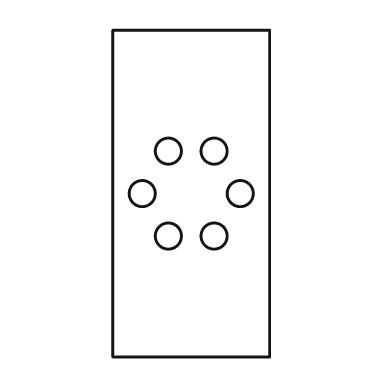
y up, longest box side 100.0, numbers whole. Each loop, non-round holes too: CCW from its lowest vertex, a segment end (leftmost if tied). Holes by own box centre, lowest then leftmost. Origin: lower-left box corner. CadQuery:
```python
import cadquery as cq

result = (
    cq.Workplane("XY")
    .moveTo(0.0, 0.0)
    .lineTo(48.0, 0.0)
    .lineTo(48.0, 100.0)
    .lineTo(0.0, 100.0)
    .close()
    .moveTo(17.0, 37.0)
    .circle(4.0)
    .moveTo(31.0, 37.0)
    .circle(4.0)
    .moveTo(9.0, 50.0)
    .circle(4.0)
    .moveTo(39.0, 50.0)
    .circle(4.0)
    .moveTo(17.0, 63.0)
    .circle(4.0)
    .moveTo(31.0, 63.0)
    .circle(4.0)
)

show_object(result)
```